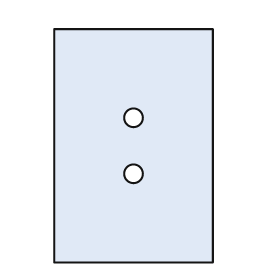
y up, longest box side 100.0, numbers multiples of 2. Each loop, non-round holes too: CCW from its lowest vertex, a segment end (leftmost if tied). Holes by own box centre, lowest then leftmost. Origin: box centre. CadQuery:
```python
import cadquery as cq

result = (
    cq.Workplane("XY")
    .moveTo(-34.0, -50.0)
    .lineTo(34.0, -50.0)
    .lineTo(34.0, 50.0)
    .lineTo(-34.0, 50.0)
    .close()
    .moveTo(0.0, -12.0)
    .circle(4.0)
    .moveTo(0.0, 12.0)
    .circle(4.0)
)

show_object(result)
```